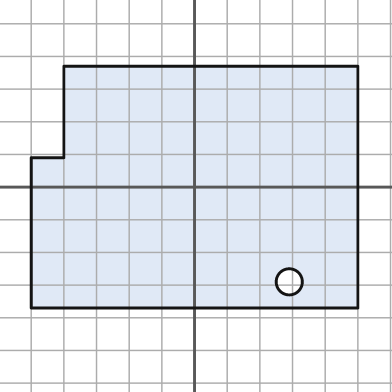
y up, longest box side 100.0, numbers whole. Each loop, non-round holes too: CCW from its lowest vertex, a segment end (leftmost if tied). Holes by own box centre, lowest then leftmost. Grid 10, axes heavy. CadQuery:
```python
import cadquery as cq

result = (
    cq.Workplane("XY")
    .moveTo(-50.0, -37.0)
    .lineTo(50.0, -37.0)
    .lineTo(50.0, 37.0)
    .lineTo(-40.0, 37.0)
    .lineTo(-40.0, 9.0)
    .lineTo(-50.0, 9.0)
    .close()
    .moveTo(29.0, -29.0)
    .circle(4.0)
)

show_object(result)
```